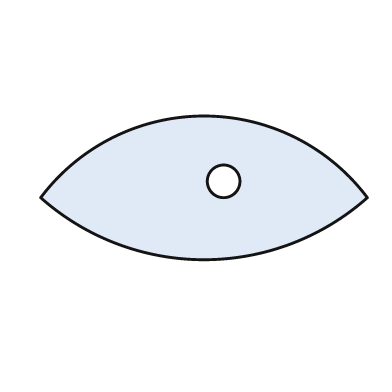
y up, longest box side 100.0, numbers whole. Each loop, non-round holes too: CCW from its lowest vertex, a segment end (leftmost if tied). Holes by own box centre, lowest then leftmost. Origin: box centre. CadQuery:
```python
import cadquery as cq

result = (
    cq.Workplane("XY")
    .moveTo(-50.0, -3.0)
    .threePointArc((0.0, -22.0), (50.0, -3.0))
    .threePointArc((0.0, 22.0), (-50.0, -3.0))
    .close()
    .moveTo(6.0, 2.0)
    .circle(5.0)
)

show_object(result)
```